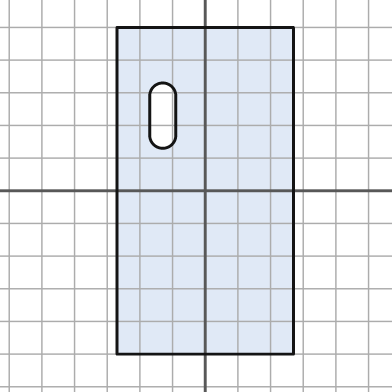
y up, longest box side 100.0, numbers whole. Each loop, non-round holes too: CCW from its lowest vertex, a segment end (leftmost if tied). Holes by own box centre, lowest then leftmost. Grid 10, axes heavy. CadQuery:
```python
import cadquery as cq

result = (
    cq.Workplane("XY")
    .moveTo(-27.0, -50.0)
    .lineTo(27.0, -50.0)
    .lineTo(27.0, 50.0)
    .lineTo(-27.0, 50.0)
    .close()
    .moveTo(-17.0, 17.0)
    .threePointArc((-13.0, 13.0), (-9.0, 17.0))
    .lineTo(-9.0, 29.0)
    .threePointArc((-13.0, 33.0), (-17.0, 29.0))
    .close()
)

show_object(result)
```